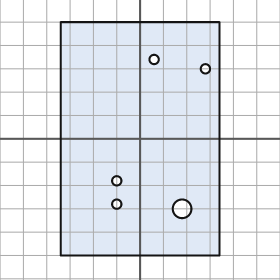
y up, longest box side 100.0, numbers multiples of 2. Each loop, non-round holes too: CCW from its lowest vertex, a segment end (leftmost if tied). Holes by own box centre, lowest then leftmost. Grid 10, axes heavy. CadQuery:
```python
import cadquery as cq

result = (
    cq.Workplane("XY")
    .moveTo(-34.0, -50.0)
    .lineTo(34.0, -50.0)
    .lineTo(34.0, 50.0)
    .lineTo(-34.0, 50.0)
    .close()
    .moveTo(18.0, -30.0)
    .circle(4.0)
    .moveTo(-10.0, -28.0)
    .circle(2.0)
    .moveTo(-10.0, -18.0)
    .circle(2.0)
    .moveTo(28.0, 30.0)
    .circle(2.0)
    .moveTo(6.0, 34.0)
    .circle(2.0)
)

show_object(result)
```